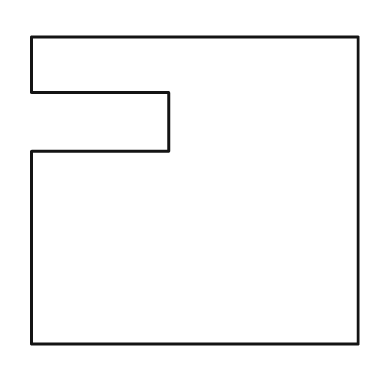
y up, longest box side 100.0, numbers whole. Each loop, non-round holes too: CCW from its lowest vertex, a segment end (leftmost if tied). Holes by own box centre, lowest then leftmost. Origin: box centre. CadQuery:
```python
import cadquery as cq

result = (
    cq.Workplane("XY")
    .moveTo(-50.0, -47.0)
    .lineTo(50.0, -47.0)
    .lineTo(50.0, 47.0)
    .lineTo(-50.0, 47.0)
    .lineTo(-50.0, 30.0)
    .lineTo(-8.0, 30.0)
    .lineTo(-8.0, 12.0)
    .lineTo(-50.0, 12.0)
    .close()
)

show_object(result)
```